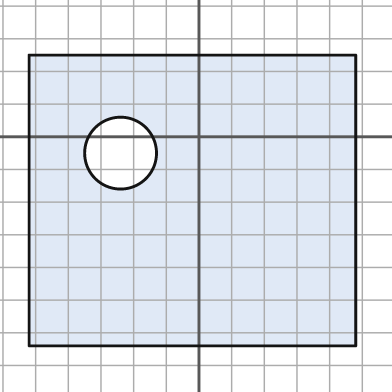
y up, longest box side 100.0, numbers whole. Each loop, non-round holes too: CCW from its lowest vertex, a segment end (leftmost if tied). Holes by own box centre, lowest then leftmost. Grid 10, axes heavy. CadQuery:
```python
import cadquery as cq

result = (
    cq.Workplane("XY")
    .moveTo(-52.0, -64.0)
    .lineTo(48.0, -64.0)
    .lineTo(48.0, 25.0)
    .lineTo(-52.0, 25.0)
    .close()
    .moveTo(-24.0, -5.0)
    .circle(11.0)
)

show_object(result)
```